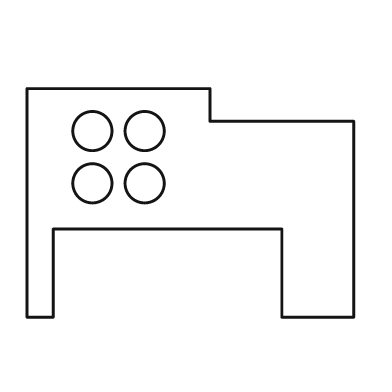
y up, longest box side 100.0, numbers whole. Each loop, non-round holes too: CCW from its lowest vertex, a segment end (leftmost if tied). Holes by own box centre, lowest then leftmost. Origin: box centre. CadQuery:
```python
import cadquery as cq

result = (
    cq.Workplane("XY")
    .moveTo(-50.0, -35.0)
    .lineTo(-42.0, -35.0)
    .lineTo(-42.0, -8.0)
    .lineTo(28.0, -8.0)
    .lineTo(28.0, -35.0)
    .lineTo(50.0, -35.0)
    .lineTo(50.0, 25.0)
    .lineTo(6.0, 25.0)
    .lineTo(6.0, 35.0)
    .lineTo(-50.0, 35.0)
    .close()
    .moveTo(-30.0, 6.0)
    .circle(6.0)
    .moveTo(-14.0, 6.0)
    .circle(6.0)
    .moveTo(-30.0, 22.0)
    .circle(6.0)
    .moveTo(-14.0, 22.0)
    .circle(6.0)
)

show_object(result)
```